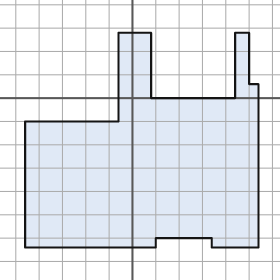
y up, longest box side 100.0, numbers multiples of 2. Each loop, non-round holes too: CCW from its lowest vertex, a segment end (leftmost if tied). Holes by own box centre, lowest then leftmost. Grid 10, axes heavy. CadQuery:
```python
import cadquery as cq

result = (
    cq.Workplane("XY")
    .moveTo(-46.0, -64.0)
    .lineTo(10.0, -64.0)
    .lineTo(10.0, -60.0)
    .lineTo(34.0, -60.0)
    .lineTo(34.0, -64.0)
    .lineTo(54.0, -64.0)
    .lineTo(54.0, 6.0)
    .lineTo(50.0, 6.0)
    .lineTo(50.0, 28.0)
    .lineTo(44.0, 28.0)
    .lineTo(44.0, 0.0)
    .lineTo(8.0, 0.0)
    .lineTo(8.0, 28.0)
    .lineTo(-6.0, 28.0)
    .lineTo(-6.0, -10.0)
    .lineTo(-46.0, -10.0)
    .close()
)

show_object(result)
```